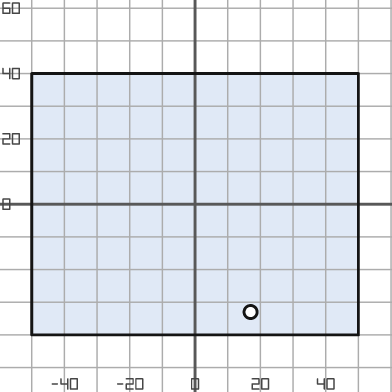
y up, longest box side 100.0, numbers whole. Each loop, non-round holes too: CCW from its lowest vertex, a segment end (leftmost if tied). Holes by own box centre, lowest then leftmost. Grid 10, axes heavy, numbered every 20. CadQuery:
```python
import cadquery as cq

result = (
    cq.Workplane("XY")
    .moveTo(-50.0, -40.0)
    .lineTo(50.0, -40.0)
    .lineTo(50.0, 40.0)
    .lineTo(-50.0, 40.0)
    .close()
    .moveTo(17.0, -33.0)
    .circle(2.0)
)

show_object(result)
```